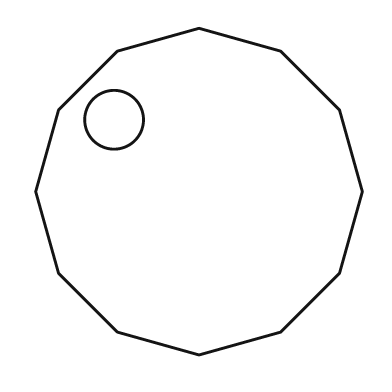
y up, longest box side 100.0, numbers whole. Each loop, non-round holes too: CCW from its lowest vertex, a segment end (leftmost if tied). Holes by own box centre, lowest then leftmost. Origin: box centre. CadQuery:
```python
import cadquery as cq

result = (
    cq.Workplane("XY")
    .moveTo(0.0, -50.0)
    .lineTo(25.0, -43.0)
    .lineTo(43.0, -25.0)
    .lineTo(50.0, 0.0)
    .lineTo(43.0, 25.0)
    .lineTo(25.0, 43.0)
    .lineTo(0.0, 50.0)
    .lineTo(-25.0, 43.0)
    .lineTo(-43.0, 25.0)
    .lineTo(-50.0, 0.0)
    .lineTo(-43.0, -25.0)
    .lineTo(-25.0, -43.0)
    .close()
    .moveTo(-26.0, 22.0)
    .circle(9.0)
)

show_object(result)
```